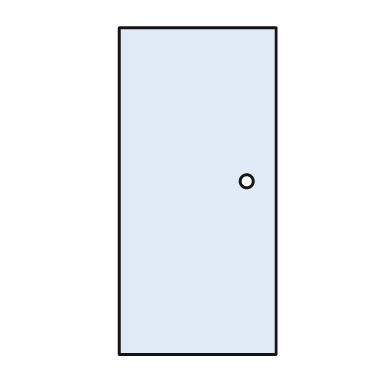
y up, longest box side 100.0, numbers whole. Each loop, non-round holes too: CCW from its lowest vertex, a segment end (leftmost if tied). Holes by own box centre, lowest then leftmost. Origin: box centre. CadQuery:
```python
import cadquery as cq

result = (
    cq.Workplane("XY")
    .moveTo(-24.0, -50.0)
    .lineTo(24.0, -50.0)
    .lineTo(24.0, 50.0)
    .lineTo(-24.0, 50.0)
    .close()
    .moveTo(15.0, 3.0)
    .circle(2.0)
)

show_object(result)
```